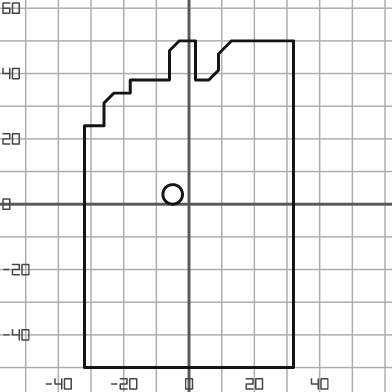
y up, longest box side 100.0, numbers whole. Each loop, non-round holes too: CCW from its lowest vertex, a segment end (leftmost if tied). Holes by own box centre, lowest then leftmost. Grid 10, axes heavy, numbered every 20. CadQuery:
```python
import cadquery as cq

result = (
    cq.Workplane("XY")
    .moveTo(-32.0, -50.0)
    .lineTo(32.0, -50.0)
    .lineTo(32.0, 50.0)
    .lineTo(13.0, 50.0)
    .lineTo(9.0, 46.0)
    .lineTo(9.0, 41.0)
    .lineTo(6.0, 38.0)
    .lineTo(2.0, 38.0)
    .lineTo(2.0, 50.0)
    .lineTo(-3.0, 50.0)
    .lineTo(-6.0, 47.0)
    .lineTo(-6.0, 38.0)
    .lineTo(-18.0, 38.0)
    .lineTo(-18.0, 34.0)
    .lineTo(-23.0, 34.0)
    .lineTo(-26.0, 31.0)
    .lineTo(-26.0, 24.0)
    .lineTo(-32.0, 24.0)
    .close()
    .moveTo(-5.0, 3.0)
    .circle(3.0)
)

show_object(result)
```